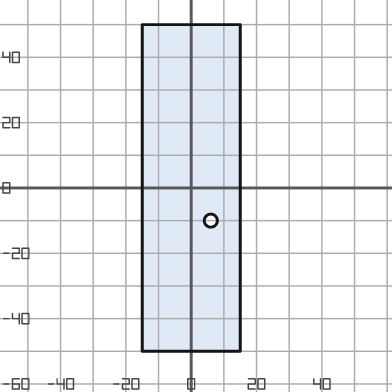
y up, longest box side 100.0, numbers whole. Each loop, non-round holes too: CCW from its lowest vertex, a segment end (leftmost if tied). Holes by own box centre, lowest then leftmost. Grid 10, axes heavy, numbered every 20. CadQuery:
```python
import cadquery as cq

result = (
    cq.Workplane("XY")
    .moveTo(-15.0, -50.0)
    .lineTo(15.0, -50.0)
    .lineTo(15.0, 50.0)
    .lineTo(-15.0, 50.0)
    .close()
    .moveTo(6.0, -10.0)
    .circle(2.0)
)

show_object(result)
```